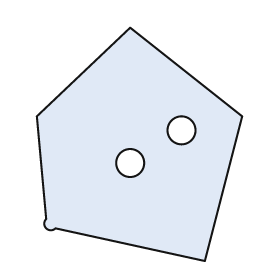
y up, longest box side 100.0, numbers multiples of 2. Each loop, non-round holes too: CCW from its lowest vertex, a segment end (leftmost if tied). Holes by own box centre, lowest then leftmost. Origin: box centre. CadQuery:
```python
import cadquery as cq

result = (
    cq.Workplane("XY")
    .moveTo(28.0, -50.0)
    .lineTo(44.0, 12.0)
    .lineTo(-4.0, 50.0)
    .lineTo(-44.0, 12.0)
    .lineTo(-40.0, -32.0)
    .threePointArc((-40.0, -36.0), (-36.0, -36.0))
    .close()
    .moveTo(-4.0, -8.0)
    .circle(6.0)
    .moveTo(18.0, 6.0)
    .circle(6.0)
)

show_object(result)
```